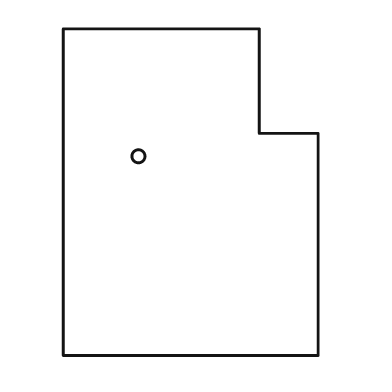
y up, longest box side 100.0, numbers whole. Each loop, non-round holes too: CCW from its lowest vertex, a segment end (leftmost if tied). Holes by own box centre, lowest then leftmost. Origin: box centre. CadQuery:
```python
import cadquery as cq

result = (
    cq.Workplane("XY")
    .moveTo(-39.0, -50.0)
    .lineTo(39.0, -50.0)
    .lineTo(39.0, 18.0)
    .lineTo(21.0, 18.0)
    .lineTo(21.0, 50.0)
    .lineTo(-39.0, 50.0)
    .close()
    .moveTo(-16.0, 11.0)
    .circle(2.0)
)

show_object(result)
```